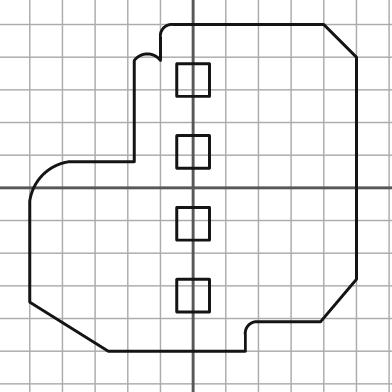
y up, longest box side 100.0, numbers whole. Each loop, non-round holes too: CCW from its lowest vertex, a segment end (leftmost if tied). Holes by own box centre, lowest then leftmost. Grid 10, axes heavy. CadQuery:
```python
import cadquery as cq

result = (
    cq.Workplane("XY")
    .moveTo(-26.0, -50.0)
    .lineTo(16.0, -50.0)
    .lineTo(16.0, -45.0)
    .threePointArc((17.0, -42.0), (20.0, -41.0))
    .lineTo(39.0, -41.0)
    .lineTo(50.0, -28.0)
    .lineTo(50.0, 40.0)
    .lineTo(40.0, 50.0)
    .lineTo(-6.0, 50.0)
    .threePointArc((-9.0, 49.0), (-10.0, 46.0))
    .lineTo(-10.0, 39.0)
    .threePointArc((-14.0, 41.0), (-18.0, 39.0))
    .lineTo(-18.0, 8.0)
    .lineTo(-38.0, 8.0)
    .threePointArc((-46.0, 4.0), (-50.0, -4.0))
    .lineTo(-50.0, -35.0)
    .close()
    .moveTo(-5.0, -38.0)
    .lineTo(5.0, -38.0)
    .lineTo(5.0, -28.0)
    .lineTo(-5.0, -28.0)
    .close()
    .moveTo(-5.0, -16.0)
    .lineTo(5.0, -16.0)
    .lineTo(5.0, -6.0)
    .lineTo(-5.0, -6.0)
    .close()
    .moveTo(-5.0, 6.0)
    .lineTo(5.0, 6.0)
    .lineTo(5.0, 16.0)
    .lineTo(-5.0, 16.0)
    .close()
    .moveTo(-5.0, 28.0)
    .lineTo(5.0, 28.0)
    .lineTo(5.0, 38.0)
    .lineTo(-5.0, 38.0)
    .close()
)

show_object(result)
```